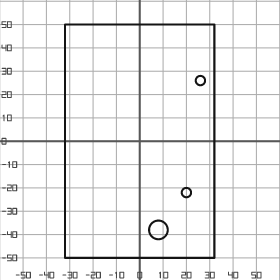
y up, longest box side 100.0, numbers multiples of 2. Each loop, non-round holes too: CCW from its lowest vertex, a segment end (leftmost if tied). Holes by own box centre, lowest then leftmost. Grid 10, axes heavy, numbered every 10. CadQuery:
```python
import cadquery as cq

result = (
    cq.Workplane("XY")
    .moveTo(-32.0, -50.0)
    .lineTo(32.0, -50.0)
    .lineTo(32.0, 50.0)
    .lineTo(-32.0, 50.0)
    .close()
    .moveTo(8.0, -38.0)
    .circle(4.0)
    .moveTo(20.0, -22.0)
    .circle(2.0)
    .moveTo(26.0, 26.0)
    .circle(2.0)
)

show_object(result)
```